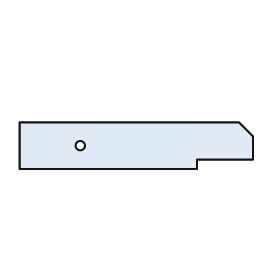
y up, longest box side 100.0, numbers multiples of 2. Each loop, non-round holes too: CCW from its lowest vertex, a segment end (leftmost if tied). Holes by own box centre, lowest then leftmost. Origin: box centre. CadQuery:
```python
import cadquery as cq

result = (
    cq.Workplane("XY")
    .moveTo(-50.0, -10.0)
    .lineTo(26.0, -10.0)
    .lineTo(26.0, -6.0)
    .lineTo(50.0, -6.0)
    .lineTo(50.0, 4.0)
    .lineTo(44.0, 10.0)
    .lineTo(-50.0, 10.0)
    .close()
    .moveTo(-24.0, 0.0)
    .circle(2.0)
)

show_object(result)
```